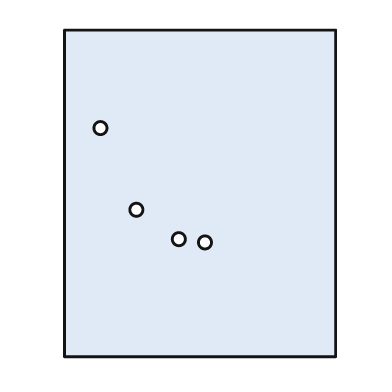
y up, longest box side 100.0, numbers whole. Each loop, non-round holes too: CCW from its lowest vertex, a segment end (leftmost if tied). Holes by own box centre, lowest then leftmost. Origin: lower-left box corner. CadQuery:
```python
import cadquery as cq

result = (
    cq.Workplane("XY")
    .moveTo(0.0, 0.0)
    .lineTo(83.0, 0.0)
    .lineTo(83.0, 100.0)
    .lineTo(0.0, 100.0)
    .close()
    .moveTo(43.0, 35.0)
    .circle(2.0)
    .moveTo(35.0, 36.0)
    .circle(2.0)
    .moveTo(22.0, 45.0)
    .circle(2.0)
    .moveTo(11.0, 70.0)
    .circle(2.0)
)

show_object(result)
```